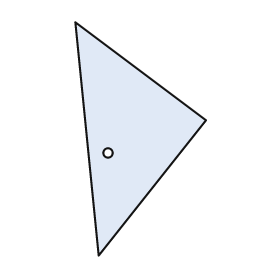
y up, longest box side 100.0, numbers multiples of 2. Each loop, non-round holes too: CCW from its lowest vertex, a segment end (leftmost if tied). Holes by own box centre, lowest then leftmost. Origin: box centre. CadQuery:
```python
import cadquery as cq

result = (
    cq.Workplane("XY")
    .moveTo(-18.0, -50.0)
    .lineTo(28.0, 8.0)
    .lineTo(-28.0, 50.0)
    .close()
    .moveTo(-14.0, -6.0)
    .circle(2.0)
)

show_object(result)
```